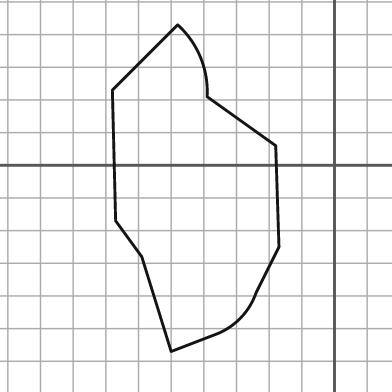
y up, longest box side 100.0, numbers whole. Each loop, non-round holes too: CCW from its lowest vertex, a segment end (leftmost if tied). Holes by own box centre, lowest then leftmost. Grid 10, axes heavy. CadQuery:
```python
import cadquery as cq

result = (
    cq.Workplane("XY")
    .moveTo(-50.0, -57.0)
    .lineTo(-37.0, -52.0)
    .threePointArc((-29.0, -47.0), (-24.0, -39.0))
    .lineTo(-17.0, -25.0)
    .lineTo(-18.0, 6.0)
    .lineTo(-39.0, 21.0)
    .threePointArc((-41.0, 33.0), (-48.0, 43.0))
    .lineTo(-68.0, 23.0)
    .lineTo(-67.0, -17.0)
    .lineTo(-59.0, -28.0)
    .close()
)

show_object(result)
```